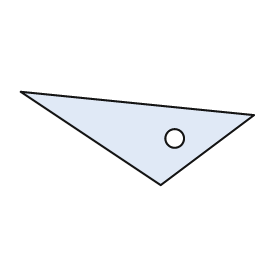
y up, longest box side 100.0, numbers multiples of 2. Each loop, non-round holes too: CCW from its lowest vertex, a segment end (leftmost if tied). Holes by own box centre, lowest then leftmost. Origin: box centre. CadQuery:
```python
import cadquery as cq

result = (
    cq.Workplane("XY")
    .moveTo(10.0, -20.0)
    .lineTo(50.0, 10.0)
    .lineTo(-50.0, 20.0)
    .close()
    .moveTo(16.0, 0.0)
    .circle(4.0)
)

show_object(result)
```